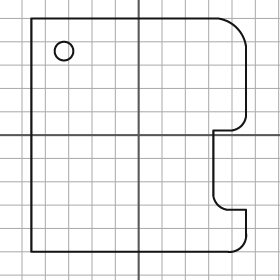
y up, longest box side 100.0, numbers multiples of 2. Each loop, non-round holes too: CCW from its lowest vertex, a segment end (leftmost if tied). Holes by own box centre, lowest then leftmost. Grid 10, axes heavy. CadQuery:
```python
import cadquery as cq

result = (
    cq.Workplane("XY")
    .moveTo(-46.0, -50.0)
    .lineTo(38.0, -50.0)
    .threePointArc((44.0, -48.0), (46.0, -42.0))
    .lineTo(46.0, -32.0)
    .lineTo(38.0, -32.0)
    .threePointArc((34.0, -30.0), (32.0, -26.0))
    .lineTo(32.0, 2.0)
    .lineTo(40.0, 2.0)
    .threePointArc((44.0, 4.0), (46.0, 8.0))
    .lineTo(46.0, 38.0)
    .threePointArc((42.0, 46.0), (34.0, 50.0))
    .lineTo(-46.0, 50.0)
    .close()
    .moveTo(-32.0, 36.0)
    .circle(4.0)
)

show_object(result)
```